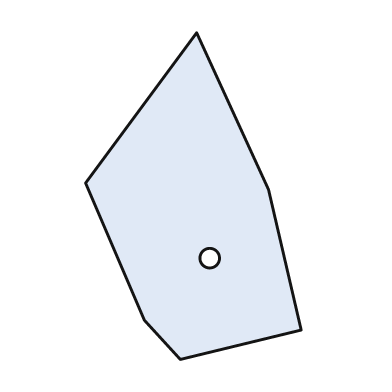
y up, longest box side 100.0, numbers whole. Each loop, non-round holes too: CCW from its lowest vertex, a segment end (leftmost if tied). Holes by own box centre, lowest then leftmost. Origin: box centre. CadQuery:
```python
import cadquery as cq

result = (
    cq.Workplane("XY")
    .moveTo(-4.0, -50.0)
    .lineTo(33.0, -41.0)
    .lineTo(23.0, 2.0)
    .lineTo(1.0, 50.0)
    .lineTo(-33.0, 4.0)
    .lineTo(-15.0, -38.0)
    .close()
    .moveTo(5.0, -19.0)
    .circle(3.0)
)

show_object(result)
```